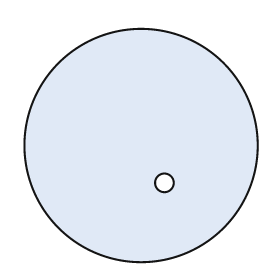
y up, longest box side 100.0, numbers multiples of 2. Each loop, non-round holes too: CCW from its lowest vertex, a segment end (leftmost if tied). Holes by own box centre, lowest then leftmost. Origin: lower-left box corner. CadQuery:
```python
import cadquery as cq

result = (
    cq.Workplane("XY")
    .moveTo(50.0, 50.0)
    .circle(50.0)
    .moveTo(60.0, 34.0)
    .circle(4.0)
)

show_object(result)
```